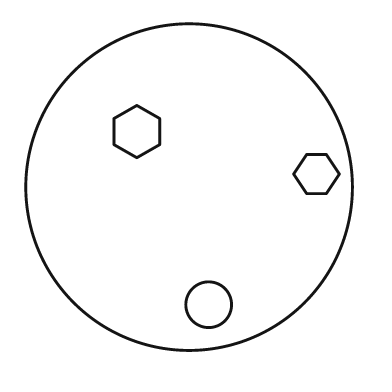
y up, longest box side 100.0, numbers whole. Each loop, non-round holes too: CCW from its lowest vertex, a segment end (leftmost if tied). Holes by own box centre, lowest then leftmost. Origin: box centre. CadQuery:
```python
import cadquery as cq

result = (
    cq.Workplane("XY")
    .moveTo(0.0, 0.0)
    .circle(50.0)
    .moveTo(6.0, -36.0)
    .circle(7.0)
    .moveTo(36.0, -2.0)
    .lineTo(42.0, -2.0)
    .lineTo(46.0, 4.0)
    .lineTo(42.0, 10.0)
    .lineTo(36.0, 10.0)
    .lineTo(32.0, 4.0)
    .close()
    .moveTo(-16.0, 9.0)
    .lineTo(-9.0, 13.0)
    .lineTo(-9.0, 21.0)
    .lineTo(-16.0, 25.0)
    .lineTo(-23.0, 21.0)
    .lineTo(-23.0, 13.0)
    .close()
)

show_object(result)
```